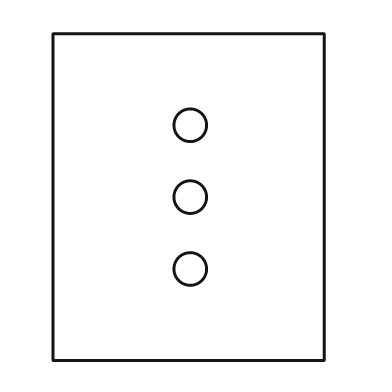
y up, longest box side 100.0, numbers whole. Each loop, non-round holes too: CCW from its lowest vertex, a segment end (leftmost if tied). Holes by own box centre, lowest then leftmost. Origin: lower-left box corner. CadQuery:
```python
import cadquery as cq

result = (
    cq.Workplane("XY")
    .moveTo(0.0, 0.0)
    .lineTo(83.0, 0.0)
    .lineTo(83.0, 100.0)
    .lineTo(0.0, 100.0)
    .close()
    .moveTo(42.0, 28.0)
    .circle(5.0)
    .moveTo(42.0, 50.0)
    .circle(5.0)
    .moveTo(42.0, 72.0)
    .circle(5.0)
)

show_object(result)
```